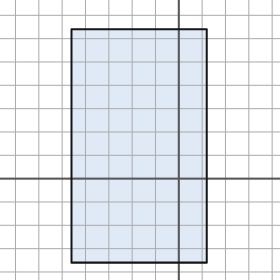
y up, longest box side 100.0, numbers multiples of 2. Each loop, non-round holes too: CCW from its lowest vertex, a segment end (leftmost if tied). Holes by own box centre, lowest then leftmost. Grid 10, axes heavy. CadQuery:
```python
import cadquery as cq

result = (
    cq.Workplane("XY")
    .moveTo(-46.0, -36.0)
    .lineTo(12.0, -36.0)
    .lineTo(12.0, 64.0)
    .lineTo(-46.0, 64.0)
    .close()
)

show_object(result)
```